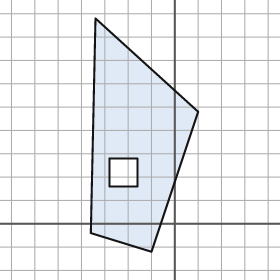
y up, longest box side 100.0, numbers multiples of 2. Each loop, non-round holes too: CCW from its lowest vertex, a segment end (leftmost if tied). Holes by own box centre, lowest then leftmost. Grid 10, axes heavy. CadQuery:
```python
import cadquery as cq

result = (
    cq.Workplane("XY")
    .moveTo(-10.0, -12.0)
    .lineTo(10.0, 48.0)
    .lineTo(-34.0, 88.0)
    .lineTo(-36.0, -4.0)
    .close()
    .moveTo(-28.0, 16.0)
    .lineTo(-16.0, 16.0)
    .lineTo(-16.0, 28.0)
    .lineTo(-28.0, 28.0)
    .close()
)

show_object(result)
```